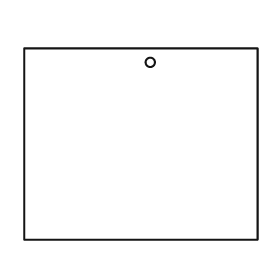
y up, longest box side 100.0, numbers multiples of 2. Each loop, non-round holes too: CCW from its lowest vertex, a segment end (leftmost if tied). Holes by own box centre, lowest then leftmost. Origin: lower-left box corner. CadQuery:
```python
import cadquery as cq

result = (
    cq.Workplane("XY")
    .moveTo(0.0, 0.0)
    .lineTo(100.0, 0.0)
    .lineTo(100.0, 82.0)
    .lineTo(0.0, 82.0)
    .close()
    .moveTo(54.0, 76.0)
    .circle(2.0)
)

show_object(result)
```